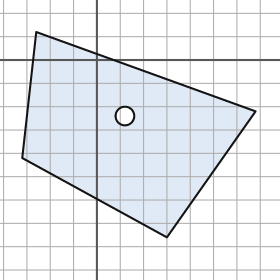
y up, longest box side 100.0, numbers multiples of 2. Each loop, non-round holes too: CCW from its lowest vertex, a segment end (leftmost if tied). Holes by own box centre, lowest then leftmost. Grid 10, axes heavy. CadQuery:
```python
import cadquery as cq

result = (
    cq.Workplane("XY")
    .moveTo(30.0, -76.0)
    .lineTo(68.0, -22.0)
    .lineTo(-26.0, 12.0)
    .lineTo(-32.0, -42.0)
    .close()
    .moveTo(12.0, -24.0)
    .circle(4.0)
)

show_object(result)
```